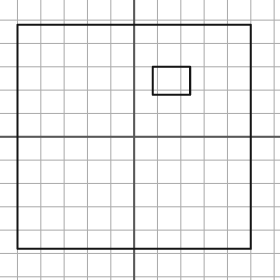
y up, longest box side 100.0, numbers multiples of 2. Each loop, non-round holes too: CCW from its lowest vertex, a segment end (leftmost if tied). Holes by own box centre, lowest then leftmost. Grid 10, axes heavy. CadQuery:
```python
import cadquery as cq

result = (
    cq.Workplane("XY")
    .moveTo(-50.0, -48.0)
    .lineTo(50.0, -48.0)
    .lineTo(50.0, 48.0)
    .lineTo(-50.0, 48.0)
    .close()
    .moveTo(8.0, 18.0)
    .lineTo(24.0, 18.0)
    .lineTo(24.0, 30.0)
    .lineTo(8.0, 30.0)
    .close()
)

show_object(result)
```